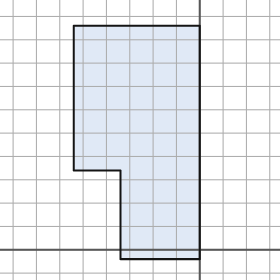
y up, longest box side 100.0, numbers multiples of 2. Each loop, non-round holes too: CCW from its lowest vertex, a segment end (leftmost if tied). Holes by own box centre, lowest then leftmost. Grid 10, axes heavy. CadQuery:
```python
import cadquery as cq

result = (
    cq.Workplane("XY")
    .moveTo(-34.0, -4.0)
    .lineTo(0.0, -4.0)
    .lineTo(0.0, 96.0)
    .lineTo(-54.0, 96.0)
    .lineTo(-54.0, 34.0)
    .lineTo(-34.0, 34.0)
    .close()
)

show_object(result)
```